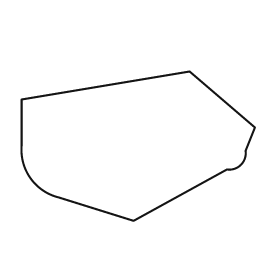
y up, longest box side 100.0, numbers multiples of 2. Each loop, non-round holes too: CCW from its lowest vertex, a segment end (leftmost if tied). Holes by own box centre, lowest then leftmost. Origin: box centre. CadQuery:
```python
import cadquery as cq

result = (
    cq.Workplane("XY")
    .moveTo(-2.0, -32.0)
    .lineTo(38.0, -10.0)
    .threePointArc((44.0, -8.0), (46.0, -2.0))
    .lineTo(50.0, 8.0)
    .lineTo(22.0, 32.0)
    .lineTo(-50.0, 20.0)
    .lineTo(-50.0, 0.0)
    .threePointArc((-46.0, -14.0), (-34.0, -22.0))
    .close()
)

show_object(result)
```